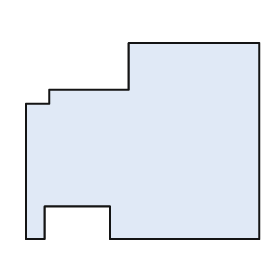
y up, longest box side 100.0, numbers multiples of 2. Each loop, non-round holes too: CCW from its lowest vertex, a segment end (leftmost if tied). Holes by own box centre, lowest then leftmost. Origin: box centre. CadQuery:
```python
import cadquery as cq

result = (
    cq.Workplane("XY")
    .moveTo(-50.0, -42.0)
    .lineTo(-42.0, -42.0)
    .lineTo(-42.0, -28.0)
    .lineTo(-14.0, -28.0)
    .lineTo(-14.0, -42.0)
    .lineTo(50.0, -42.0)
    .lineTo(50.0, 42.0)
    .lineTo(-6.0, 42.0)
    .lineTo(-6.0, 22.0)
    .lineTo(-40.0, 22.0)
    .lineTo(-40.0, 16.0)
    .lineTo(-50.0, 16.0)
    .close()
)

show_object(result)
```